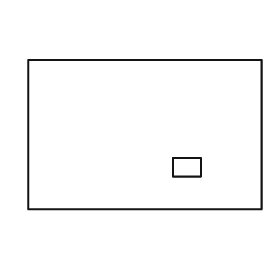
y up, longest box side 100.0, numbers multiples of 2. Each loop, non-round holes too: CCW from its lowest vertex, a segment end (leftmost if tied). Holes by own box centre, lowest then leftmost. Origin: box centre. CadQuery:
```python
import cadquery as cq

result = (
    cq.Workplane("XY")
    .moveTo(-50.0, -32.0)
    .lineTo(50.0, -32.0)
    .lineTo(50.0, 32.0)
    .lineTo(-50.0, 32.0)
    .close()
    .moveTo(12.0, -18.0)
    .lineTo(24.0, -18.0)
    .lineTo(24.0, -10.0)
    .lineTo(12.0, -10.0)
    .close()
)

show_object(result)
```